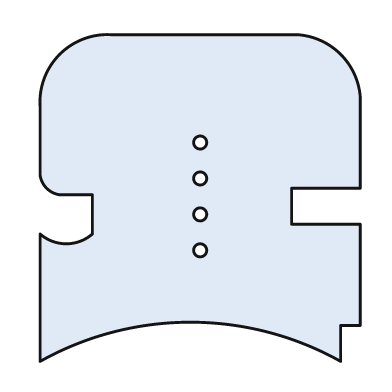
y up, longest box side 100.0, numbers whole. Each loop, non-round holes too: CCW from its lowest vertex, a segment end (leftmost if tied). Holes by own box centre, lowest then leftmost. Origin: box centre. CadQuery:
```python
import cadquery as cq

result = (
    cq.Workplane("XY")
    .moveTo(-49.0, -50.0)
    .threePointArc((-3.0, -38.0), (43.0, -50.0))
    .lineTo(43.0, -39.0)
    .lineTo(49.0, -39.0)
    .lineTo(49.0, -8.0)
    .lineTo(28.0, -8.0)
    .lineTo(28.0, 3.0)
    .lineTo(49.0, 3.0)
    .lineTo(49.0, 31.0)
    .threePointArc((43.0, 44.0), (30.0, 50.0))
    .lineTo(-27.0, 50.0)
    .threePointArc((-43.0, 44.0), (-49.0, 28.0))
    .lineTo(-49.0, 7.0)
    .threePointArc((-47.0, 3.0), (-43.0, 1.0))
    .lineTo(-33.0, 1.0)
    .lineTo(-33.0, -11.0)
    .threePointArc((-41.0, -14.0), (-49.0, -11.0))
    .close()
    .moveTo(0.0, -16.0)
    .circle(2.0)
    .moveTo(0.0, -5.0)
    .circle(2.0)
    .moveTo(0.0, 6.0)
    .circle(2.0)
    .moveTo(0.0, 17.0)
    .circle(2.0)
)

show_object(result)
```